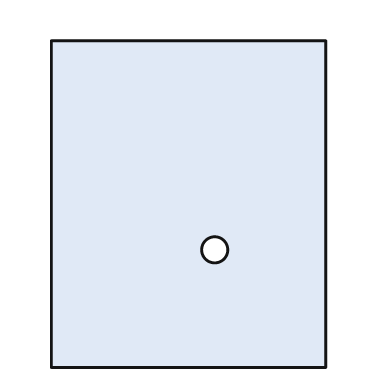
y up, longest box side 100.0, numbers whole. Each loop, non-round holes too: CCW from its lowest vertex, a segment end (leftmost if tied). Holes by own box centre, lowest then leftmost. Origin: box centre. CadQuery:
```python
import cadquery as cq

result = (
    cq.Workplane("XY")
    .moveTo(-42.0, -50.0)
    .lineTo(42.0, -50.0)
    .lineTo(42.0, 50.0)
    .lineTo(-42.0, 50.0)
    .close()
    .moveTo(8.0, -14.0)
    .circle(4.0)
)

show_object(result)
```